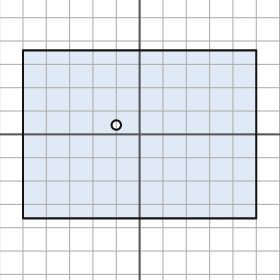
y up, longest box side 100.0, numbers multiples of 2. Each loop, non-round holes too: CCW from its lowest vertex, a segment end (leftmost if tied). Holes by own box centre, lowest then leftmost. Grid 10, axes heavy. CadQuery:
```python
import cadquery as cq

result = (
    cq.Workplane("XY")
    .moveTo(-50.0, -36.0)
    .lineTo(50.0, -36.0)
    .lineTo(50.0, 36.0)
    .lineTo(-50.0, 36.0)
    .close()
    .moveTo(-10.0, 4.0)
    .circle(2.0)
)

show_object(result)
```